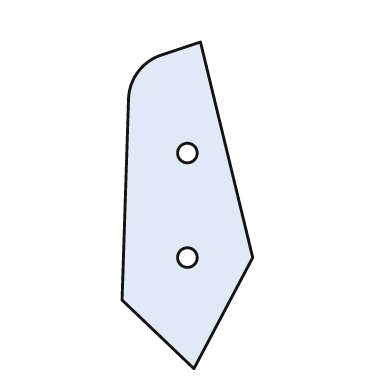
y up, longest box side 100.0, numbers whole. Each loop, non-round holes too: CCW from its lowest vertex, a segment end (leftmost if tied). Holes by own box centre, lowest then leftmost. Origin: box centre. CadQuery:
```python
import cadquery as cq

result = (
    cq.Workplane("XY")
    .moveTo(2.0, -50.0)
    .lineTo(20.0, -16.0)
    .lineTo(4.0, 50.0)
    .lineTo(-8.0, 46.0)
    .threePointArc((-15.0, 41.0), (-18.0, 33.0))
    .lineTo(-20.0, -29.0)
    .close()
    .moveTo(0.0, -16.0)
    .circle(3.0)
    .moveTo(0.0, 16.0)
    .circle(3.0)
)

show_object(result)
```